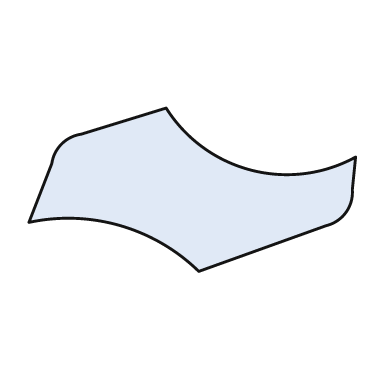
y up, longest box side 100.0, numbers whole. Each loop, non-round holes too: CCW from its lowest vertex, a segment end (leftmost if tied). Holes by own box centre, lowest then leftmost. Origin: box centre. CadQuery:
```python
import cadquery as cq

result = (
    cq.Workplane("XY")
    .moveTo(2.0, -25.0)
    .lineTo(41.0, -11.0)
    .threePointArc((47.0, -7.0), (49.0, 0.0))
    .lineTo(50.0, 10.0)
    .threePointArc((18.0, 6.0), (-8.0, 25.0))
    .lineTo(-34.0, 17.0)
    .threePointArc((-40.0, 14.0), (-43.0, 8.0))
    .lineTo(-50.0, -10.0)
    .threePointArc((-22.0, -11.0), (2.0, -25.0))
    .close()
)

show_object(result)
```